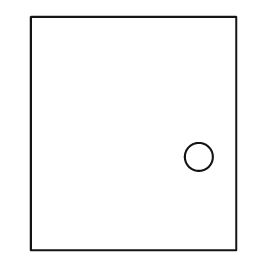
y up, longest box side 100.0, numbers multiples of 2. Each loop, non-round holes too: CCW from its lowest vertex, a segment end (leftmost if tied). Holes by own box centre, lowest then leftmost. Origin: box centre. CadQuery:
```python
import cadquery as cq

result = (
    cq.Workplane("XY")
    .moveTo(-44.0, -50.0)
    .lineTo(44.0, -50.0)
    .lineTo(44.0, 50.0)
    .lineTo(-44.0, 50.0)
    .close()
    .moveTo(28.0, -10.0)
    .circle(6.0)
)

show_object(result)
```